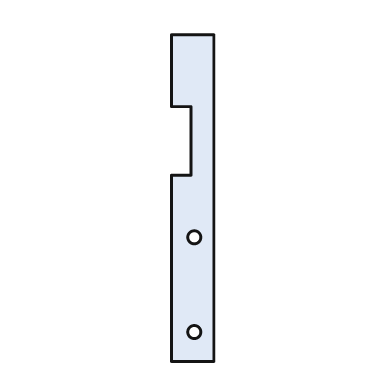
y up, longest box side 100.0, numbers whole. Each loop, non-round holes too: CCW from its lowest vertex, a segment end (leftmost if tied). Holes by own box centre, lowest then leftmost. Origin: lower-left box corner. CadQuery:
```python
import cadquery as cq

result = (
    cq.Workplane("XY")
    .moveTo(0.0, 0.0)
    .lineTo(13.0, 0.0)
    .lineTo(13.0, 100.0)
    .lineTo(0.0, 100.0)
    .lineTo(0.0, 78.0)
    .lineTo(6.0, 78.0)
    .lineTo(6.0, 57.0)
    .lineTo(0.0, 57.0)
    .close()
    .moveTo(7.0, 9.0)
    .circle(2.0)
    .moveTo(7.0, 38.0)
    .circle(2.0)
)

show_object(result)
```